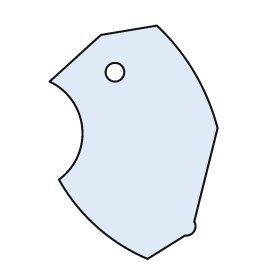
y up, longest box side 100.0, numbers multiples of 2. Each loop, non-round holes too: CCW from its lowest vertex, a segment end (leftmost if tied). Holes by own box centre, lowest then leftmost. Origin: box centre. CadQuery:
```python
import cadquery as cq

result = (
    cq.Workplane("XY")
    .moveTo(6.0, -50.0)
    .lineTo(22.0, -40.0)
    .threePointArc((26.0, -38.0), (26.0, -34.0))
    .lineTo(36.0, 6.0)
    .threePointArc((26.0, 30.0), (10.0, 50.0))
    .lineTo(-14.0, 46.0)
    .lineTo(-36.0, 26.0)
    .threePointArc((-22.0, 6.0), (-32.0, -16.0))
    .threePointArc((-16.0, -36.0), (6.0, -50.0))
    .close()
    .moveTo(-8.0, 30.0)
    .circle(4.0)
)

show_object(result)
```